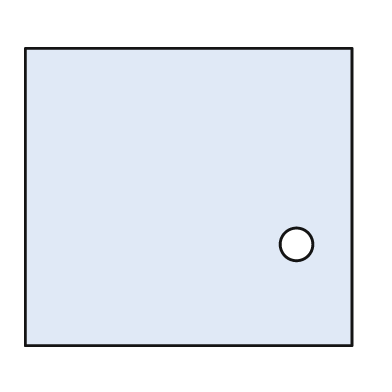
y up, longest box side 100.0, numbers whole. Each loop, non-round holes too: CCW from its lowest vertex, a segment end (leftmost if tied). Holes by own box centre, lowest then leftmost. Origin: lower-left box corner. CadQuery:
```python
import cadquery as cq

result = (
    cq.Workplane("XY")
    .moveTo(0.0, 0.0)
    .lineTo(100.0, 0.0)
    .lineTo(100.0, 91.0)
    .lineTo(0.0, 91.0)
    .close()
    .moveTo(83.0, 31.0)
    .circle(5.0)
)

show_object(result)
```